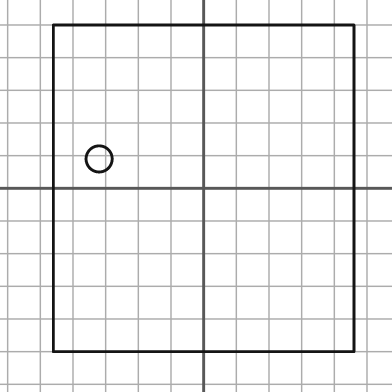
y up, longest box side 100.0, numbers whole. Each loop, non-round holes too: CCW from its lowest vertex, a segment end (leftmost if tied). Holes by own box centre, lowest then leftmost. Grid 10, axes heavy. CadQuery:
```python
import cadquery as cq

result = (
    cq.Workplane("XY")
    .moveTo(-46.0, -50.0)
    .lineTo(46.0, -50.0)
    .lineTo(46.0, 50.0)
    .lineTo(-46.0, 50.0)
    .close()
    .moveTo(-32.0, 9.0)
    .circle(4.0)
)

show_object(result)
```